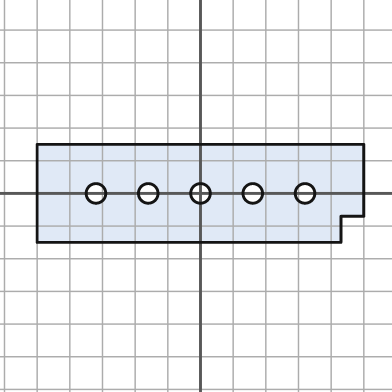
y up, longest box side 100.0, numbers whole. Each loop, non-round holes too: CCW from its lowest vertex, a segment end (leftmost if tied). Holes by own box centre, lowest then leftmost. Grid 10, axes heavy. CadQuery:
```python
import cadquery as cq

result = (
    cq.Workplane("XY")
    .moveTo(-50.0, -15.0)
    .lineTo(43.0, -15.0)
    .lineTo(43.0, -7.0)
    .lineTo(50.0, -7.0)
    .lineTo(50.0, 15.0)
    .lineTo(-50.0, 15.0)
    .close()
    .moveTo(-32.0, 0.0)
    .circle(3.0)
    .moveTo(-16.0, 0.0)
    .circle(3.0)
    .moveTo(0.0, 0.0)
    .circle(3.0)
    .moveTo(16.0, 0.0)
    .circle(3.0)
    .moveTo(32.0, 0.0)
    .circle(3.0)
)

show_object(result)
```